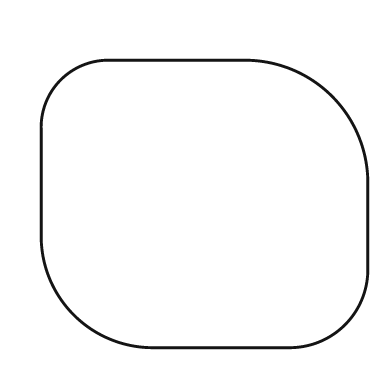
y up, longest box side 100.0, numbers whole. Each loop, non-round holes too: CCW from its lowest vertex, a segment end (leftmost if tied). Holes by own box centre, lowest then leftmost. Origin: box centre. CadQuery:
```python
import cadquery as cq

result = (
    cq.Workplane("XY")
    .moveTo(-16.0, -44.0)
    .lineTo(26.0, -44.0)
    .threePointArc((43.0, -37.0), (50.0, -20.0))
    .lineTo(50.0, 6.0)
    .threePointArc((39.0, 33.0), (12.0, 44.0))
    .lineTo(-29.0, 44.0)
    .threePointArc((-44.0, 38.0), (-50.0, 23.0))
    .lineTo(-50.0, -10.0)
    .threePointArc((-40.0, -34.0), (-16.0, -44.0))
    .close()
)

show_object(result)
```